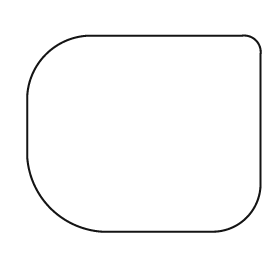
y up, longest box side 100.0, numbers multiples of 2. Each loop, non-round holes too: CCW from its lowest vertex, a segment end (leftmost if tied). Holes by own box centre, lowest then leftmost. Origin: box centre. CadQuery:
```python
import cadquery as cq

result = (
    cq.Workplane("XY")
    .moveTo(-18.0, -42.0)
    .lineTo(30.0, -42.0)
    .threePointArc((44.0, -36.0), (50.0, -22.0))
    .lineTo(50.0, 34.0)
    .threePointArc((48.0, 40.0), (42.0, 42.0))
    .lineTo(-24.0, 42.0)
    .threePointArc((-42.0, 34.0), (-50.0, 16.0))
    .lineTo(-50.0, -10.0)
    .threePointArc((-40.0, -32.0), (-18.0, -42.0))
    .close()
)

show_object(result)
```